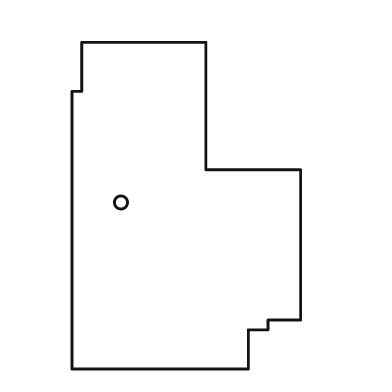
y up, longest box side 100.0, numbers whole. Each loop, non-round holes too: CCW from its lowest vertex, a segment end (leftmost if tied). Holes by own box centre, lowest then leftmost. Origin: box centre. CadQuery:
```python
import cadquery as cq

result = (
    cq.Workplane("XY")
    .moveTo(-35.0, -50.0)
    .lineTo(19.0, -50.0)
    .lineTo(19.0, -38.0)
    .lineTo(25.0, -38.0)
    .lineTo(25.0, -35.0)
    .lineTo(35.0, -35.0)
    .lineTo(35.0, 11.0)
    .lineTo(6.0, 11.0)
    .lineTo(6.0, 50.0)
    .lineTo(-32.0, 50.0)
    .lineTo(-32.0, 35.0)
    .lineTo(-35.0, 35.0)
    .close()
    .moveTo(-20.0, 1.0)
    .circle(2.0)
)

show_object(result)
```